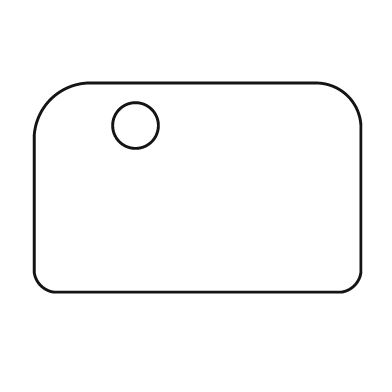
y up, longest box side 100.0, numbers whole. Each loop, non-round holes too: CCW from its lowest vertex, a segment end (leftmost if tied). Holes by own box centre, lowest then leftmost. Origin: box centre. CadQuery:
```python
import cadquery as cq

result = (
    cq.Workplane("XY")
    .moveTo(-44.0, -32.0)
    .lineTo(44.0, -32.0)
    .threePointArc((48.0, -30.0), (50.0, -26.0))
    .lineTo(50.0, 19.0)
    .threePointArc((46.0, 28.0), (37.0, 32.0))
    .lineTo(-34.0, 32.0)
    .threePointArc((-45.0, 27.0), (-50.0, 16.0))
    .lineTo(-50.0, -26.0)
    .threePointArc((-48.0, -30.0), (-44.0, -32.0))
    .close()
    .moveTo(-19.0, 19.0)
    .circle(7.0)
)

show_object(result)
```